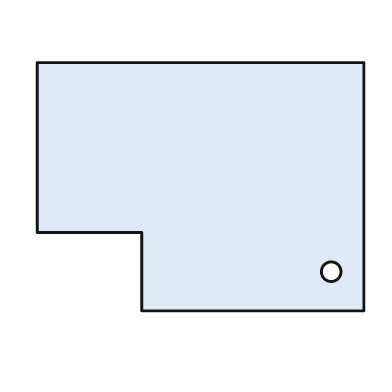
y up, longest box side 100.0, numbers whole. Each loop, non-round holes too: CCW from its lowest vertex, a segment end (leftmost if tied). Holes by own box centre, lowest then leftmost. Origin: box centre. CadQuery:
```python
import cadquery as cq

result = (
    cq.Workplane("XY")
    .moveTo(-18.0, -38.0)
    .lineTo(50.0, -38.0)
    .lineTo(50.0, 38.0)
    .lineTo(-50.0, 38.0)
    .lineTo(-50.0, -14.0)
    .lineTo(-18.0, -14.0)
    .close()
    .moveTo(40.0, -26.0)
    .circle(3.0)
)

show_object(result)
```